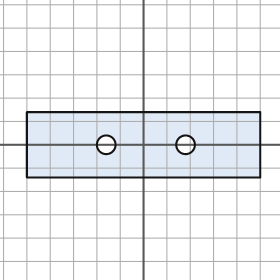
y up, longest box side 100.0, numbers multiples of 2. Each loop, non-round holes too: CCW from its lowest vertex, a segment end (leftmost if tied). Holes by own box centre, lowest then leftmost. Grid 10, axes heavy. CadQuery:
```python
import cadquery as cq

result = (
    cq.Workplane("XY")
    .moveTo(-50.0, -14.0)
    .lineTo(50.0, -14.0)
    .lineTo(50.0, 14.0)
    .lineTo(-50.0, 14.0)
    .close()
    .moveTo(-16.0, 0.0)
    .circle(4.0)
    .moveTo(18.0, 0.0)
    .circle(4.0)
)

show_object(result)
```